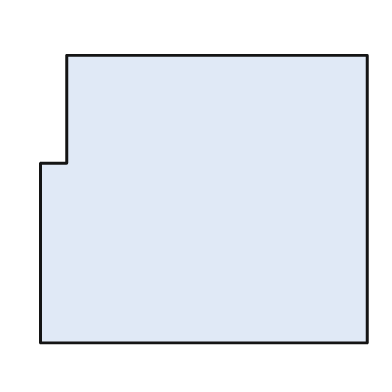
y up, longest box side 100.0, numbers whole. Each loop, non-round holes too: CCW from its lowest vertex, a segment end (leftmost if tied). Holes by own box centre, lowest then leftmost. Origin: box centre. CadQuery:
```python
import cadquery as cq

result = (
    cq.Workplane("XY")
    .moveTo(-50.0, -44.0)
    .lineTo(50.0, -44.0)
    .lineTo(50.0, 44.0)
    .lineTo(-42.0, 44.0)
    .lineTo(-42.0, 11.0)
    .lineTo(-50.0, 11.0)
    .close()
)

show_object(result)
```